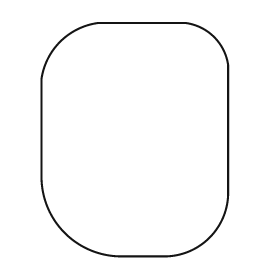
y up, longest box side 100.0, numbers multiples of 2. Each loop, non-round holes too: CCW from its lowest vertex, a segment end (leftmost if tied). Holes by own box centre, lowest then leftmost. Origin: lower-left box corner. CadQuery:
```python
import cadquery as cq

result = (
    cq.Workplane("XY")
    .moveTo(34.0, 0.0)
    .lineTo(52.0, 0.0)
    .threePointArc((72.0, 8.0), (80.0, 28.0))
    .lineTo(80.0, 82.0)
    .threePointArc((74.0, 94.0), (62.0, 100.0))
    .lineTo(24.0, 100.0)
    .threePointArc((8.0, 92.0), (0.0, 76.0))
    .lineTo(0.0, 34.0)
    .threePointArc((10.0, 10.0), (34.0, 0.0))
    .close()
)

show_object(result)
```